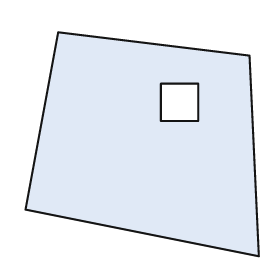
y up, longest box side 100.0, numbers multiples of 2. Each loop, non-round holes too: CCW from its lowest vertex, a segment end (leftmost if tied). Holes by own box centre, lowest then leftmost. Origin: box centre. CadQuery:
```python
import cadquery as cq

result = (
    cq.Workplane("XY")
    .moveTo(50.0, -48.0)
    .lineTo(46.0, 38.0)
    .lineTo(-36.0, 48.0)
    .lineTo(-50.0, -28.0)
    .close()
    .moveTo(8.0, 10.0)
    .lineTo(24.0, 10.0)
    .lineTo(24.0, 26.0)
    .lineTo(8.0, 26.0)
    .close()
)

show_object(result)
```